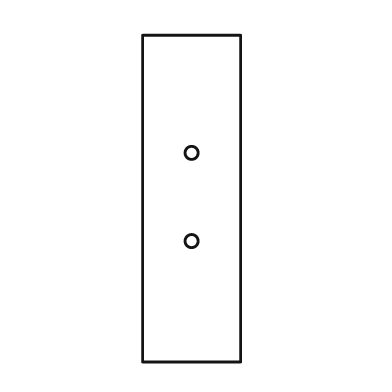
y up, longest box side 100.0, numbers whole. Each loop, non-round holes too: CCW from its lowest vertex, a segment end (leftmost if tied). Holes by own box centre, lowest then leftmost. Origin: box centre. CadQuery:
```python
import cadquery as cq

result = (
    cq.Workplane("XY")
    .moveTo(-15.0, -50.0)
    .lineTo(15.0, -50.0)
    .lineTo(15.0, 50.0)
    .lineTo(-15.0, 50.0)
    .close()
    .moveTo(0.0, -13.0)
    .circle(2.0)
    .moveTo(0.0, 14.0)
    .circle(2.0)
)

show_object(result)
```